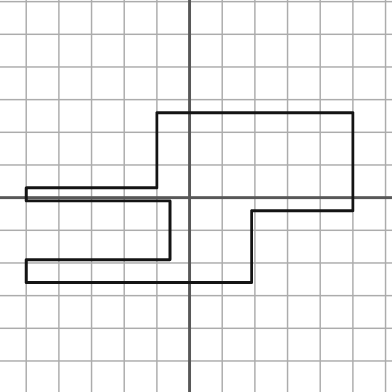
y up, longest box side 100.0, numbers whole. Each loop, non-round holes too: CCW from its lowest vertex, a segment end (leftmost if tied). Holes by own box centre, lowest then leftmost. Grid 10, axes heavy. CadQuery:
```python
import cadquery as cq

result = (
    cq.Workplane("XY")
    .moveTo(-50.0, -26.0)
    .lineTo(19.0, -26.0)
    .lineTo(19.0, -4.0)
    .lineTo(50.0, -4.0)
    .lineTo(50.0, 26.0)
    .lineTo(-10.0, 26.0)
    .lineTo(-10.0, 3.0)
    .lineTo(-50.0, 3.0)
    .lineTo(-50.0, -1.0)
    .lineTo(-6.0, -1.0)
    .lineTo(-6.0, -19.0)
    .lineTo(-50.0, -19.0)
    .close()
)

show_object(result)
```